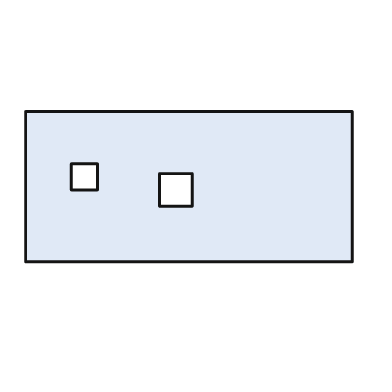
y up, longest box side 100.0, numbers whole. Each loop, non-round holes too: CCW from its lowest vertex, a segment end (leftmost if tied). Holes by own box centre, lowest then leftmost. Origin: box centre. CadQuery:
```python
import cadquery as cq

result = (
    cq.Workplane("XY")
    .moveTo(-50.0, -23.0)
    .lineTo(50.0, -23.0)
    .lineTo(50.0, 23.0)
    .lineTo(-50.0, 23.0)
    .close()
    .moveTo(-9.0, -6.0)
    .lineTo(1.0, -6.0)
    .lineTo(1.0, 4.0)
    .lineTo(-9.0, 4.0)
    .close()
    .moveTo(-36.0, -1.0)
    .lineTo(-28.0, -1.0)
    .lineTo(-28.0, 7.0)
    .lineTo(-36.0, 7.0)
    .close()
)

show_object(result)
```